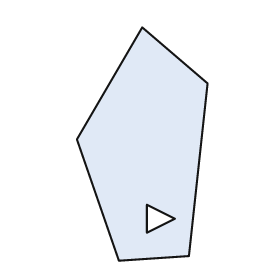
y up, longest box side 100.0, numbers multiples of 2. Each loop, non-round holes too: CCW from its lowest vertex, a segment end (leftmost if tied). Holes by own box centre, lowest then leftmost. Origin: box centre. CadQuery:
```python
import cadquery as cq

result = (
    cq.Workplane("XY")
    .moveTo(-10.0, -50.0)
    .lineTo(20.0, -48.0)
    .lineTo(28.0, 26.0)
    .lineTo(0.0, 50.0)
    .lineTo(-28.0, 2.0)
    .close()
    .moveTo(2.0, -38.0)
    .lineTo(14.0, -32.0)
    .lineTo(2.0, -26.0)
    .close()
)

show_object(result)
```